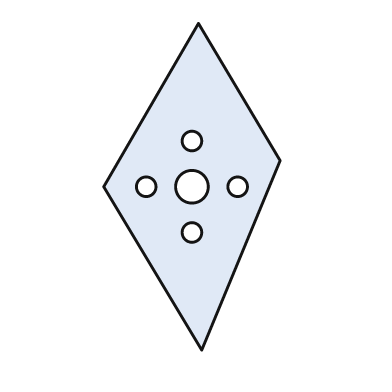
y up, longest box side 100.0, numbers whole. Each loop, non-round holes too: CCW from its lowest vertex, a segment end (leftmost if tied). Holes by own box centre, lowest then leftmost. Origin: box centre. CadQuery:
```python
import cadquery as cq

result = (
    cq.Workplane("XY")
    .moveTo(3.0, -50.0)
    .lineTo(27.0, 8.0)
    .lineTo(2.0, 50.0)
    .lineTo(-27.0, 0.0)
    .close()
    .moveTo(0.0, -14.0)
    .circle(3.0)
    .moveTo(-14.0, 0.0)
    .circle(3.0)
    .moveTo(0.0, 0.0)
    .circle(5.0)
    .moveTo(14.0, 0.0)
    .circle(3.0)
    .moveTo(0.0, 14.0)
    .circle(3.0)
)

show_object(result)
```